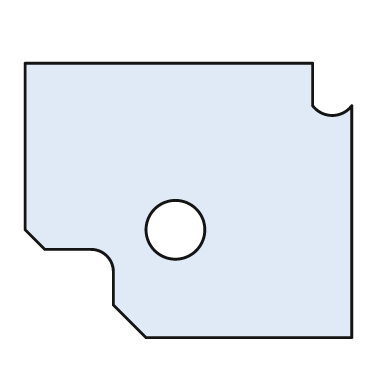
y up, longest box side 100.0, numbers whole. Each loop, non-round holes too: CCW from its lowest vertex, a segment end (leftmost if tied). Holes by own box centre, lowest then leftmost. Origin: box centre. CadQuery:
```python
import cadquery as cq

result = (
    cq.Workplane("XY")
    .moveTo(-13.0, -42.0)
    .lineTo(50.0, -42.0)
    .lineTo(50.0, 29.0)
    .threePointArc((44.0, 26.0), (38.0, 29.0))
    .lineTo(38.0, 42.0)
    .lineTo(-50.0, 42.0)
    .lineTo(-50.0, -9.0)
    .lineTo(-44.0, -15.0)
    .lineTo(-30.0, -15.0)
    .threePointArc((-25.0, -17.0), (-23.0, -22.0))
    .lineTo(-23.0, -32.0)
    .close()
    .moveTo(-4.0, -9.0)
    .circle(9.0)
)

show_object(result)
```